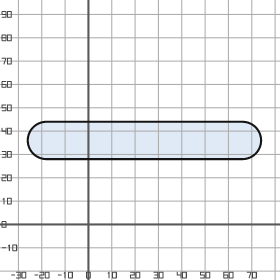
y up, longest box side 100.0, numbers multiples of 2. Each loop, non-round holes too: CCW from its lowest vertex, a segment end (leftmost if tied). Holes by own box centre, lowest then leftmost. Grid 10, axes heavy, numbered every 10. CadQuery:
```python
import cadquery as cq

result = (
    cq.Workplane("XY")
    .moveTo(-18.0, 28.0)
    .lineTo(66.0, 28.0)
    .threePointArc((74.0, 36.0), (66.0, 44.0))
    .lineTo(-18.0, 44.0)
    .threePointArc((-26.0, 36.0), (-18.0, 28.0))
    .close()
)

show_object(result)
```